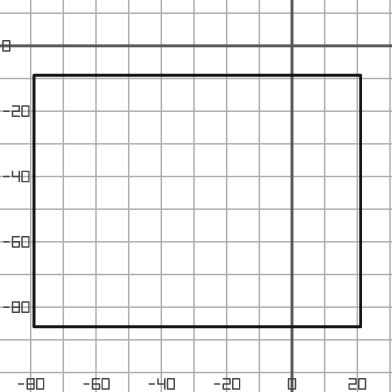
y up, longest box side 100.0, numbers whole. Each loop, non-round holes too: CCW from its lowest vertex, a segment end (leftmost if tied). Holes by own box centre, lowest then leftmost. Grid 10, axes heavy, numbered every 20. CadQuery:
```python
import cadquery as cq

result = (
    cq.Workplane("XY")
    .moveTo(-79.0, -86.0)
    .lineTo(21.0, -86.0)
    .lineTo(21.0, -9.0)
    .lineTo(-79.0, -9.0)
    .close()
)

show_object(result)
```